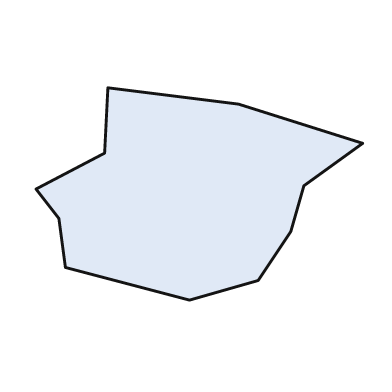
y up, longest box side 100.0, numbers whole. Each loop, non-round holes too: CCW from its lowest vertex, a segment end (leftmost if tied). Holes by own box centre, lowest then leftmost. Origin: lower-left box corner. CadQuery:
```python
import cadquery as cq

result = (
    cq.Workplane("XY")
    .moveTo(47.0, 0.0)
    .lineTo(68.0, 6.0)
    .lineTo(78.0, 21.0)
    .lineTo(82.0, 35.0)
    .lineTo(100.0, 48.0)
    .lineTo(62.0, 60.0)
    .lineTo(22.0, 65.0)
    .lineTo(21.0, 45.0)
    .lineTo(0.0, 34.0)
    .lineTo(7.0, 25.0)
    .lineTo(9.0, 10.0)
    .close()
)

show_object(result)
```